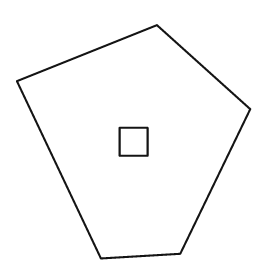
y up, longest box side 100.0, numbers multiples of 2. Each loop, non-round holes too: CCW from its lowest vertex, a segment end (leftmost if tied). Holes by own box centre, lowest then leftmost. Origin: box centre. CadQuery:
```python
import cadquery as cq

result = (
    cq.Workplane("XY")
    .moveTo(-14.0, -50.0)
    .lineTo(20.0, -48.0)
    .lineTo(50.0, 14.0)
    .lineTo(10.0, 50.0)
    .lineTo(-50.0, 26.0)
    .close()
    .moveTo(-6.0, -6.0)
    .lineTo(6.0, -6.0)
    .lineTo(6.0, 6.0)
    .lineTo(-6.0, 6.0)
    .close()
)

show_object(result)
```